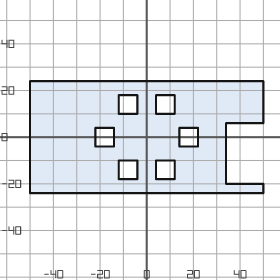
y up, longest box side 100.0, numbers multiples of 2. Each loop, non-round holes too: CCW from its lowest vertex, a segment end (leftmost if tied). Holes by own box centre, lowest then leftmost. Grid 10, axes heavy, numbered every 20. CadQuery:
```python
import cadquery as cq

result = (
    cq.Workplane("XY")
    .moveTo(-50.0, -24.0)
    .lineTo(50.0, -24.0)
    .lineTo(50.0, -20.0)
    .lineTo(34.0, -20.0)
    .lineTo(34.0, 6.0)
    .lineTo(50.0, 6.0)
    .lineTo(50.0, 24.0)
    .lineTo(-50.0, 24.0)
    .close()
    .moveTo(-12.0, -18.0)
    .lineTo(-4.0, -18.0)
    .lineTo(-4.0, -10.0)
    .lineTo(-12.0, -10.0)
    .close()
    .moveTo(4.0, -18.0)
    .lineTo(12.0, -18.0)
    .lineTo(12.0, -10.0)
    .lineTo(4.0, -10.0)
    .close()
    .moveTo(-22.0, -4.0)
    .lineTo(-14.0, -4.0)
    .lineTo(-14.0, 4.0)
    .lineTo(-22.0, 4.0)
    .close()
    .moveTo(14.0, -4.0)
    .lineTo(22.0, -4.0)
    .lineTo(22.0, 4.0)
    .lineTo(14.0, 4.0)
    .close()
    .moveTo(-12.0, 10.0)
    .lineTo(-4.0, 10.0)
    .lineTo(-4.0, 18.0)
    .lineTo(-12.0, 18.0)
    .close()
    .moveTo(4.0, 10.0)
    .lineTo(12.0, 10.0)
    .lineTo(12.0, 18.0)
    .lineTo(4.0, 18.0)
    .close()
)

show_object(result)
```